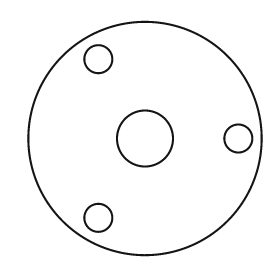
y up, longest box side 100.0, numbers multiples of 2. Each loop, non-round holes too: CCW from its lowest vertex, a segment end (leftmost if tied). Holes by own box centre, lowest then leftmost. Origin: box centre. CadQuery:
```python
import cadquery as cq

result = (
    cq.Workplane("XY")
    .moveTo(0.0, 0.0)
    .circle(50.0)
    .moveTo(-20.0, -34.0)
    .circle(6.0)
    .moveTo(0.0, 0.0)
    .circle(12.0)
    .moveTo(40.0, 0.0)
    .circle(6.0)
    .moveTo(-20.0, 34.0)
    .circle(6.0)
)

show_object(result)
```